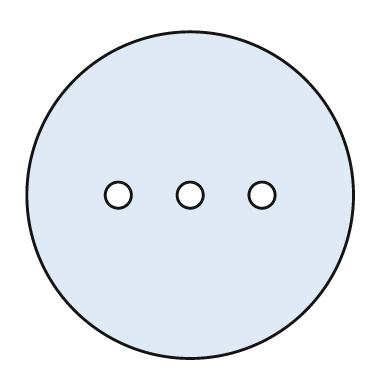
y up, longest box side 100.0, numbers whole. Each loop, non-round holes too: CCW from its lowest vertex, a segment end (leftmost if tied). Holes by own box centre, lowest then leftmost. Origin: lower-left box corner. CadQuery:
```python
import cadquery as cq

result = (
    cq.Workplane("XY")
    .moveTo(50.0, 50.0)
    .circle(50.0)
    .moveTo(28.0, 50.0)
    .circle(4.0)
    .moveTo(50.0, 50.0)
    .circle(4.0)
    .moveTo(72.0, 50.0)
    .circle(4.0)
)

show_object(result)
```